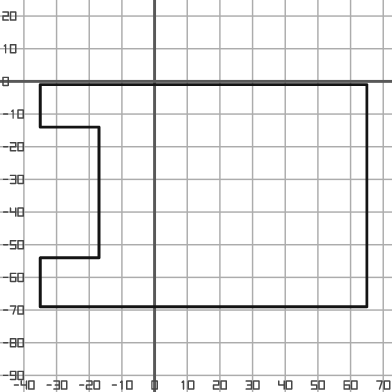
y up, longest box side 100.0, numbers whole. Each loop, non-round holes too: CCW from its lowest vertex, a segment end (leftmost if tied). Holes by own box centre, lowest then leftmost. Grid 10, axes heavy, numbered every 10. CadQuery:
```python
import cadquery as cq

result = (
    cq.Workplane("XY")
    .moveTo(-35.0, -69.0)
    .lineTo(65.0, -69.0)
    .lineTo(65.0, -1.0)
    .lineTo(-35.0, -1.0)
    .lineTo(-35.0, -14.0)
    .lineTo(-17.0, -14.0)
    .lineTo(-17.0, -54.0)
    .lineTo(-35.0, -54.0)
    .close()
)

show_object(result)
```